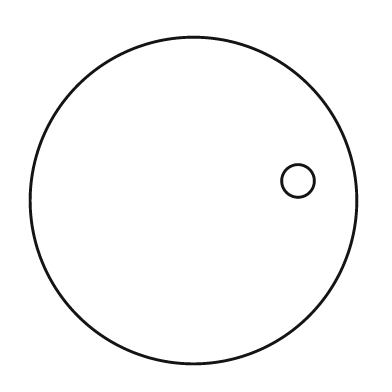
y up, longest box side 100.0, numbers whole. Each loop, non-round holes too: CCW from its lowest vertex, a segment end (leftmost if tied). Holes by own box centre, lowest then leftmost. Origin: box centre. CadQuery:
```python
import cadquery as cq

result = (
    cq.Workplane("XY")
    .moveTo(0.0, 0.0)
    .circle(50.0)
    .moveTo(32.0, 6.0)
    .circle(5.0)
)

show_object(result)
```